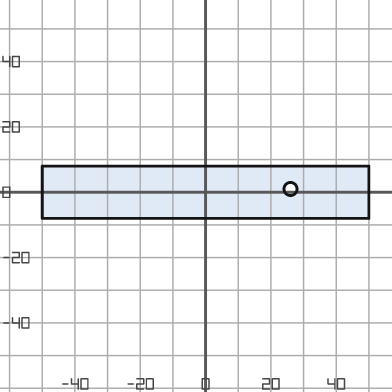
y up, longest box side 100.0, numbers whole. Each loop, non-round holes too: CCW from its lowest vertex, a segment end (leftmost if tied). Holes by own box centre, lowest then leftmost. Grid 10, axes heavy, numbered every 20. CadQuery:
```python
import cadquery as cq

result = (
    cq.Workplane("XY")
    .moveTo(-50.0, -8.0)
    .lineTo(50.0, -8.0)
    .lineTo(50.0, 8.0)
    .lineTo(-50.0, 8.0)
    .close()
    .moveTo(26.0, 1.0)
    .circle(2.0)
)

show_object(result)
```